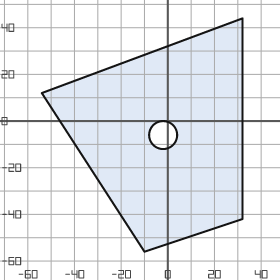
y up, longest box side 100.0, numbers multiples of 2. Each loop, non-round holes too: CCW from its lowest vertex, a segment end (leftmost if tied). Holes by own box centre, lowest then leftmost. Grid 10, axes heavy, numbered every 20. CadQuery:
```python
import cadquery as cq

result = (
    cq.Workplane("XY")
    .moveTo(-10.0, -56.0)
    .lineTo(32.0, -42.0)
    .lineTo(32.0, 44.0)
    .lineTo(-54.0, 12.0)
    .close()
    .moveTo(-2.0, -6.0)
    .circle(6.0)
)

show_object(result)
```